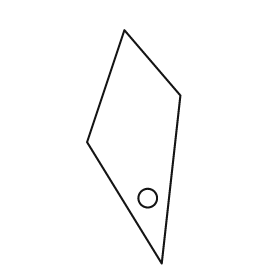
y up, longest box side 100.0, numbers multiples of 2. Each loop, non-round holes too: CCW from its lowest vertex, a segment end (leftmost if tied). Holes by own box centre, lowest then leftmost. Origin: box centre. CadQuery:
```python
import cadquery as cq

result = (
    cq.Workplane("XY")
    .moveTo(12.0, -50.0)
    .lineTo(20.0, 22.0)
    .lineTo(-4.0, 50.0)
    .lineTo(-20.0, 2.0)
    .close()
    .moveTo(6.0, -22.0)
    .circle(4.0)
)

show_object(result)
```